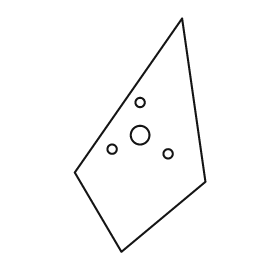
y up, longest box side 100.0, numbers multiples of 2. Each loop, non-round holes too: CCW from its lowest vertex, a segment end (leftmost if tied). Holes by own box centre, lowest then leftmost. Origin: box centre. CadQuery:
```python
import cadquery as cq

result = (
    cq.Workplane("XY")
    .moveTo(-8.0, -50.0)
    .lineTo(28.0, -20.0)
    .lineTo(18.0, 50.0)
    .lineTo(-28.0, -16.0)
    .close()
    .moveTo(12.0, -8.0)
    .circle(2.0)
    .moveTo(-12.0, -6.0)
    .circle(2.0)
    .moveTo(0.0, 0.0)
    .circle(4.0)
    .moveTo(0.0, 14.0)
    .circle(2.0)
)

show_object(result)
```